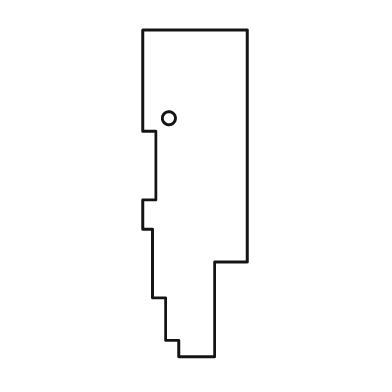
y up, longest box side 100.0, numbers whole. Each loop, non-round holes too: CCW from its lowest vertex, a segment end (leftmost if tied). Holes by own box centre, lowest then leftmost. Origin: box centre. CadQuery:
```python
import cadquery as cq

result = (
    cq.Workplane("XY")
    .moveTo(-5.0, -50.0)
    .lineTo(6.0, -50.0)
    .lineTo(6.0, -21.0)
    .lineTo(16.0, -21.0)
    .lineTo(16.0, 50.0)
    .lineTo(-16.0, 50.0)
    .lineTo(-16.0, 19.0)
    .lineTo(-12.0, 19.0)
    .lineTo(-12.0, -2.0)
    .lineTo(-16.0, -2.0)
    .lineTo(-16.0, -11.0)
    .lineTo(-13.0, -11.0)
    .lineTo(-13.0, -32.0)
    .lineTo(-9.0, -32.0)
    .lineTo(-9.0, -45.0)
    .lineTo(-5.0, -45.0)
    .close()
    .moveTo(-8.0, 23.0)
    .circle(2.0)
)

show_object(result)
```